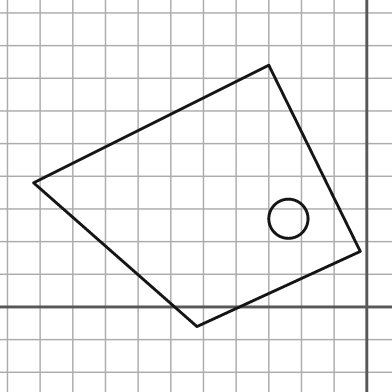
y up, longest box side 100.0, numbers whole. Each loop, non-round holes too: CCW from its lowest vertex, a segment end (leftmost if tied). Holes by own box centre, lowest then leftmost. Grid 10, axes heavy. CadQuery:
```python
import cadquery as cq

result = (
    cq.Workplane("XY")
    .moveTo(-52.0, -6.0)
    .lineTo(-2.0, 17.0)
    .lineTo(-30.0, 74.0)
    .lineTo(-102.0, 38.0)
    .close()
    .moveTo(-24.0, 27.0)
    .circle(6.0)
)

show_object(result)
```